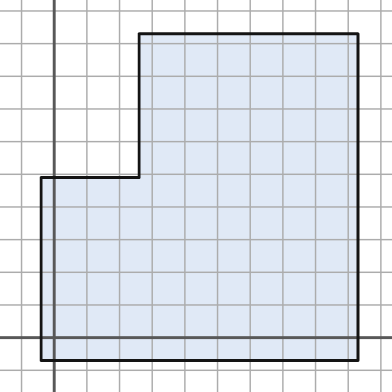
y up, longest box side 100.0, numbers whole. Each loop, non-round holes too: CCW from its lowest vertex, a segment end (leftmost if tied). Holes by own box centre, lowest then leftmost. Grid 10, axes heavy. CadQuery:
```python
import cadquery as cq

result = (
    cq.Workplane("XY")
    .moveTo(-4.0, -7.0)
    .lineTo(93.0, -7.0)
    .lineTo(93.0, 93.0)
    .lineTo(26.0, 93.0)
    .lineTo(26.0, 49.0)
    .lineTo(-4.0, 49.0)
    .close()
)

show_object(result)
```